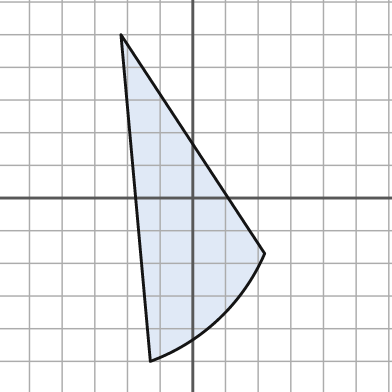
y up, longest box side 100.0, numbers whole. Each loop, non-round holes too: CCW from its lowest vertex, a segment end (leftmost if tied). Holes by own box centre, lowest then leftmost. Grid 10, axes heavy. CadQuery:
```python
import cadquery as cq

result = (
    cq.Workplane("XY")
    .moveTo(-13.0, -50.0)
    .threePointArc((8.0, -37.0), (22.0, -17.0))
    .lineTo(-22.0, 50.0)
    .close()
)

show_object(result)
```